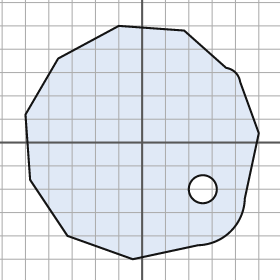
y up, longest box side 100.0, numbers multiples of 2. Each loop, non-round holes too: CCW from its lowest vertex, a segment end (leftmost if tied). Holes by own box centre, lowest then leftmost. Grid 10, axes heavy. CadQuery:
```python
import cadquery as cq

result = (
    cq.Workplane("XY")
    .moveTo(-4.0, -50.0)
    .lineTo(24.0, -44.0)
    .threePointArc((38.0, -38.0), (44.0, -24.0))
    .lineTo(50.0, 4.0)
    .lineTo(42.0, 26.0)
    .threePointArc((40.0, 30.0), (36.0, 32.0))
    .lineTo(18.0, 48.0)
    .lineTo(-10.0, 50.0)
    .lineTo(-36.0, 36.0)
    .lineTo(-50.0, 12.0)
    .lineTo(-48.0, -16.0)
    .lineTo(-32.0, -40.0)
    .close()
    .moveTo(26.0, -20.0)
    .circle(6.0)
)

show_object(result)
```